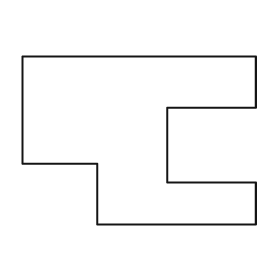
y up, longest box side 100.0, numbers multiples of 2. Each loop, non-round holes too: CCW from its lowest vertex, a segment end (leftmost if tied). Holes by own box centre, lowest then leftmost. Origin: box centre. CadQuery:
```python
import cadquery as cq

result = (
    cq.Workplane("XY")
    .moveTo(-18.0, -36.0)
    .lineTo(50.0, -36.0)
    .lineTo(50.0, -18.0)
    .lineTo(12.0, -18.0)
    .lineTo(12.0, 14.0)
    .lineTo(50.0, 14.0)
    .lineTo(50.0, 36.0)
    .lineTo(-50.0, 36.0)
    .lineTo(-50.0, -10.0)
    .lineTo(-18.0, -10.0)
    .close()
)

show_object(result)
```